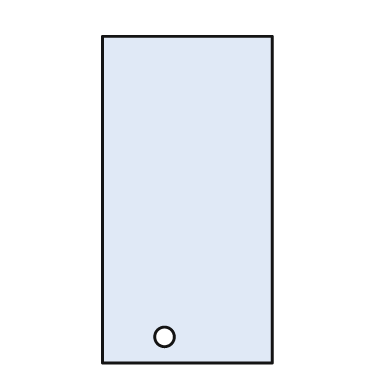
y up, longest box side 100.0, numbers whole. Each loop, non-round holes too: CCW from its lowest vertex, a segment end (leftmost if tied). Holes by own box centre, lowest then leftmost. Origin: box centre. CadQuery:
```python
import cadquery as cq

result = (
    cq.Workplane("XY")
    .moveTo(-26.0, -50.0)
    .lineTo(26.0, -50.0)
    .lineTo(26.0, 50.0)
    .lineTo(-26.0, 50.0)
    .close()
    .moveTo(-7.0, -42.0)
    .circle(3.0)
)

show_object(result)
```